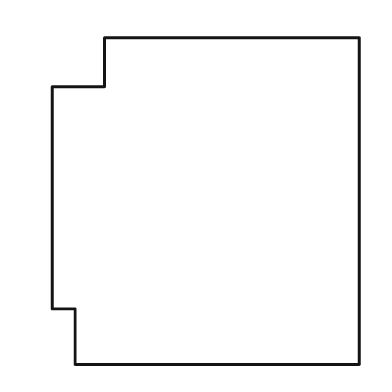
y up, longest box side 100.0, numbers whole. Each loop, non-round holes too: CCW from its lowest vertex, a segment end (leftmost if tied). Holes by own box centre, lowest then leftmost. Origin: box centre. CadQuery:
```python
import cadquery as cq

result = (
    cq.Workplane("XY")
    .moveTo(-40.0, -50.0)
    .lineTo(47.0, -50.0)
    .lineTo(47.0, 50.0)
    .lineTo(-31.0, 50.0)
    .lineTo(-31.0, 35.0)
    .lineTo(-47.0, 35.0)
    .lineTo(-47.0, -33.0)
    .lineTo(-40.0, -33.0)
    .close()
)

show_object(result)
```